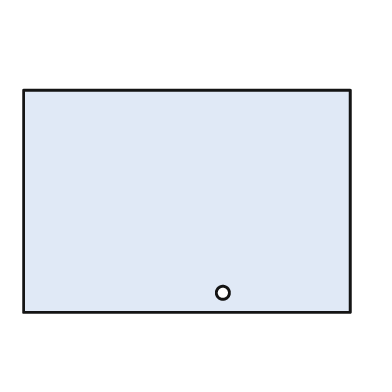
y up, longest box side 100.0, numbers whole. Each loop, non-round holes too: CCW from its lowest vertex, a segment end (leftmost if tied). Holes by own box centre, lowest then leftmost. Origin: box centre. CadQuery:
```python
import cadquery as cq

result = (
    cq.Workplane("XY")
    .moveTo(-50.0, -34.0)
    .lineTo(50.0, -34.0)
    .lineTo(50.0, 34.0)
    .lineTo(-50.0, 34.0)
    .close()
    .moveTo(11.0, -28.0)
    .circle(2.0)
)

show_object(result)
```